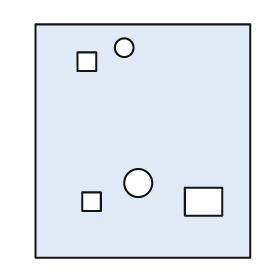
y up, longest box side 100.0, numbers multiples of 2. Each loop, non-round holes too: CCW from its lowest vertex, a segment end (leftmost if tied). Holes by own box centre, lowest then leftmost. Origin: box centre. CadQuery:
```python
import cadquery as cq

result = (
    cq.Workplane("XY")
    .moveTo(-46.0, -50.0)
    .lineTo(46.0, -50.0)
    .lineTo(46.0, 50.0)
    .lineTo(-46.0, 50.0)
    .close()
    .moveTo(-26.0, -30.0)
    .lineTo(-18.0, -30.0)
    .lineTo(-18.0, -22.0)
    .lineTo(-26.0, -22.0)
    .close()
    .moveTo(18.0, -32.0)
    .lineTo(34.0, -32.0)
    .lineTo(34.0, -20.0)
    .lineTo(18.0, -20.0)
    .close()
    .moveTo(-2.0, -18.0)
    .circle(6.0)
    .moveTo(-28.0, 30.0)
    .lineTo(-20.0, 30.0)
    .lineTo(-20.0, 38.0)
    .lineTo(-28.0, 38.0)
    .close()
    .moveTo(-8.0, 40.0)
    .circle(4.0)
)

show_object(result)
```